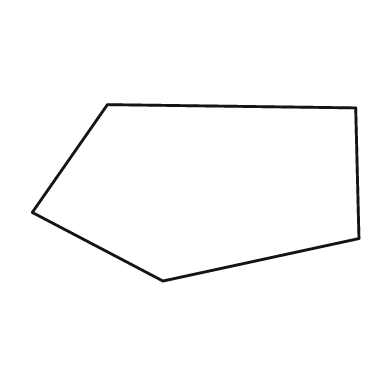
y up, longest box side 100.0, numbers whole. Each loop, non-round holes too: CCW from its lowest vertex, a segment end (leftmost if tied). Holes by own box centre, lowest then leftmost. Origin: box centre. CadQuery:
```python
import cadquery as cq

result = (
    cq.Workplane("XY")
    .moveTo(-10.0, -27.0)
    .lineTo(50.0, -14.0)
    .lineTo(49.0, 26.0)
    .lineTo(-27.0, 27.0)
    .lineTo(-50.0, -6.0)
    .close()
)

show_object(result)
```